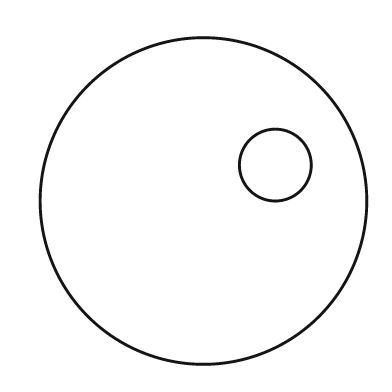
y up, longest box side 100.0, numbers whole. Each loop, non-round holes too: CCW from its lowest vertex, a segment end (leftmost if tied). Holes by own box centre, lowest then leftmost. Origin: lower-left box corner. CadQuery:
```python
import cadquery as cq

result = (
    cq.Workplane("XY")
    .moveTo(50.0, 50.0)
    .circle(50.0)
    .moveTo(72.0, 61.0)
    .circle(11.0)
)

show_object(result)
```